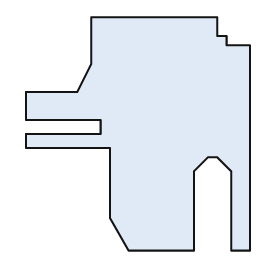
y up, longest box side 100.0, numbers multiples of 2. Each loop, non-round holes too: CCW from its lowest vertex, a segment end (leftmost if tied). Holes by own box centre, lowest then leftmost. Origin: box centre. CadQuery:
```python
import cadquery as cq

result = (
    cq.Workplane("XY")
    .moveTo(-4.0, -50.0)
    .lineTo(24.0, -50.0)
    .lineTo(24.0, -16.0)
    .lineTo(30.0, -10.0)
    .lineTo(34.0, -10.0)
    .lineTo(40.0, -16.0)
    .lineTo(40.0, -50.0)
    .lineTo(48.0, -50.0)
    .lineTo(48.0, 38.0)
    .lineTo(38.0, 38.0)
    .lineTo(38.0, 42.0)
    .lineTo(34.0, 42.0)
    .lineTo(34.0, 50.0)
    .lineTo(-20.0, 50.0)
    .lineTo(-20.0, 30.0)
    .lineTo(-26.0, 18.0)
    .lineTo(-48.0, 18.0)
    .lineTo(-48.0, 6.0)
    .lineTo(-16.0, 6.0)
    .lineTo(-16.0, 0.0)
    .lineTo(-48.0, 0.0)
    .lineTo(-48.0, -6.0)
    .lineTo(-12.0, -6.0)
    .lineTo(-12.0, -36.0)
    .close()
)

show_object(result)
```